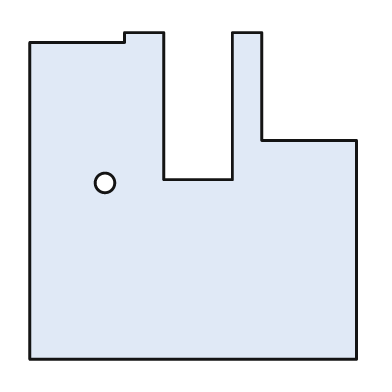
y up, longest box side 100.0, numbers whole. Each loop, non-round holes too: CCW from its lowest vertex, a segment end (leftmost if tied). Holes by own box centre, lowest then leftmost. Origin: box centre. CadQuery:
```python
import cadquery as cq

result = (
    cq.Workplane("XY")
    .moveTo(-50.0, -50.0)
    .lineTo(50.0, -50.0)
    .lineTo(50.0, 17.0)
    .lineTo(21.0, 17.0)
    .lineTo(21.0, 50.0)
    .lineTo(12.0, 50.0)
    .lineTo(12.0, 5.0)
    .lineTo(-9.0, 5.0)
    .lineTo(-9.0, 50.0)
    .lineTo(-21.0, 50.0)
    .lineTo(-21.0, 47.0)
    .lineTo(-50.0, 47.0)
    .close()
    .moveTo(-27.0, 4.0)
    .circle(3.0)
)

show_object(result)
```